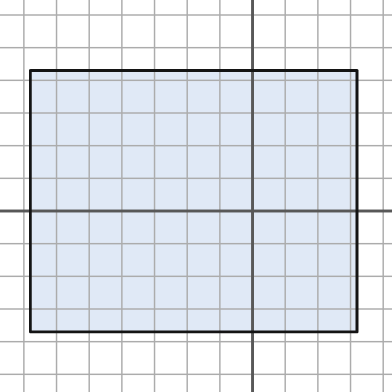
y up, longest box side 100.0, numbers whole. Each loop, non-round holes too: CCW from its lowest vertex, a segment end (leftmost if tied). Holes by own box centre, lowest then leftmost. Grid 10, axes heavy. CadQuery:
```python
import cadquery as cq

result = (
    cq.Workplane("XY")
    .moveTo(-68.0, -37.0)
    .lineTo(32.0, -37.0)
    .lineTo(32.0, 43.0)
    .lineTo(-68.0, 43.0)
    .close()
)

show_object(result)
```